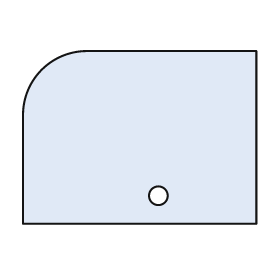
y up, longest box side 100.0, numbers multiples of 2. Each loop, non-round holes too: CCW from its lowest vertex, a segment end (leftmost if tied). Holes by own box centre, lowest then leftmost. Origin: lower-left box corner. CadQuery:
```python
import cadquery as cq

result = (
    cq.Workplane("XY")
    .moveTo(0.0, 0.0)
    .lineTo(100.0, 0.0)
    .lineTo(100.0, 74.0)
    .lineTo(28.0, 74.0)
    .threePointArc((8.0, 66.0), (0.0, 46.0))
    .close()
    .moveTo(58.0, 12.0)
    .circle(4.0)
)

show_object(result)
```